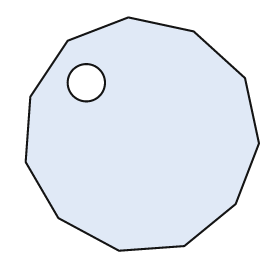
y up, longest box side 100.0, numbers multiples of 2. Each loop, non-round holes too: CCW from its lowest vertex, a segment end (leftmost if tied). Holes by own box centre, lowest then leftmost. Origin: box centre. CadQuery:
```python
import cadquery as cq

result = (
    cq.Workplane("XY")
    .moveTo(-10.0, -50.0)
    .lineTo(18.0, -48.0)
    .lineTo(40.0, -30.0)
    .lineTo(50.0, -4.0)
    .lineTo(44.0, 24.0)
    .lineTo(22.0, 44.0)
    .lineTo(-6.0, 50.0)
    .lineTo(-32.0, 40.0)
    .lineTo(-48.0, 16.0)
    .lineTo(-50.0, -12.0)
    .lineTo(-36.0, -36.0)
    .close()
    .moveTo(-24.0, 22.0)
    .circle(8.0)
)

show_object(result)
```